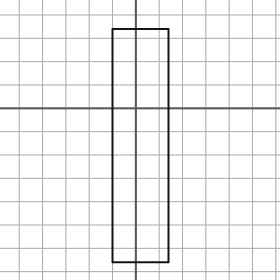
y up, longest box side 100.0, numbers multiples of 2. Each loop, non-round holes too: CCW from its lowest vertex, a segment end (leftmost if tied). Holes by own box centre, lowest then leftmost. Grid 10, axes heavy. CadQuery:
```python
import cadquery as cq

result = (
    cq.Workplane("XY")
    .moveTo(-10.0, -66.0)
    .lineTo(14.0, -66.0)
    .lineTo(14.0, 34.0)
    .lineTo(-10.0, 34.0)
    .close()
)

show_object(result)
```